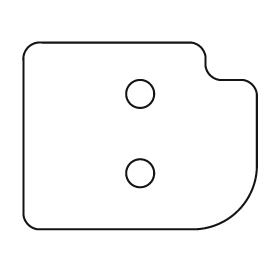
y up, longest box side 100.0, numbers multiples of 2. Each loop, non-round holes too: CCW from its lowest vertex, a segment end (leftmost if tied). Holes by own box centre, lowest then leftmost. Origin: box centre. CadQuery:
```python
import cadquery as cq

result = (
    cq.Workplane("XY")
    .moveTo(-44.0, -40.0)
    .lineTo(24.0, -40.0)
    .threePointArc((42.0, -32.0), (50.0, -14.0))
    .lineTo(50.0, 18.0)
    .threePointArc((48.0, 22.0), (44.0, 24.0))
    .lineTo(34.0, 24.0)
    .threePointArc((30.0, 26.0), (28.0, 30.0))
    .lineTo(28.0, 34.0)
    .threePointArc((26.0, 38.0), (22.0, 40.0))
    .lineTo(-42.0, 40.0)
    .threePointArc((-48.0, 38.0), (-50.0, 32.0))
    .lineTo(-50.0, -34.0)
    .threePointArc((-48.0, -38.0), (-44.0, -40.0))
    .close()
    .moveTo(0.0, -16.0)
    .circle(6.0)
    .moveTo(0.0, 18.0)
    .circle(6.0)
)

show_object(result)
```